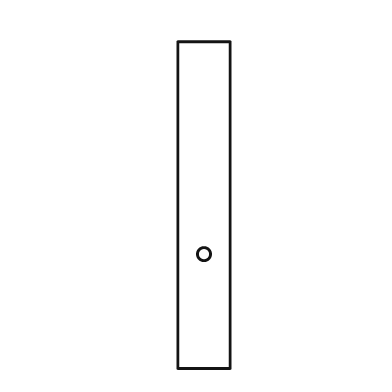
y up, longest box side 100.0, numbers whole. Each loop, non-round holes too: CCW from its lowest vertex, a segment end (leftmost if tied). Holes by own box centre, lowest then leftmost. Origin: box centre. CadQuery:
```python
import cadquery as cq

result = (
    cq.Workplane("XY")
    .moveTo(-8.0, -50.0)
    .lineTo(8.0, -50.0)
    .lineTo(8.0, 50.0)
    .lineTo(-8.0, 50.0)
    .close()
    .moveTo(0.0, -15.0)
    .circle(2.0)
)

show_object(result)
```